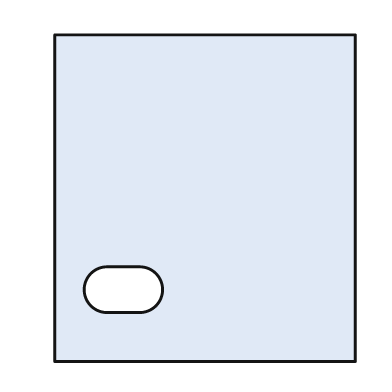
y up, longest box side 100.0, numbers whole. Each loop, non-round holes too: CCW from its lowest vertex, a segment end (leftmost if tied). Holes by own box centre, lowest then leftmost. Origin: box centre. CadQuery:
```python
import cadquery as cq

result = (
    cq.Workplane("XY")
    .moveTo(-46.0, -50.0)
    .lineTo(46.0, -50.0)
    .lineTo(46.0, 50.0)
    .lineTo(-46.0, 50.0)
    .close()
    .moveTo(-30.0, -35.0)
    .lineTo(-20.0, -35.0)
    .threePointArc((-13.0, -28.0), (-20.0, -21.0))
    .lineTo(-30.0, -21.0)
    .threePointArc((-37.0, -28.0), (-30.0, -35.0))
    .close()
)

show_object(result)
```